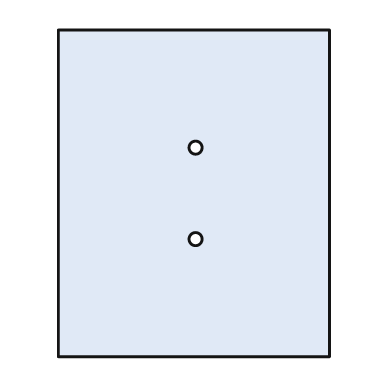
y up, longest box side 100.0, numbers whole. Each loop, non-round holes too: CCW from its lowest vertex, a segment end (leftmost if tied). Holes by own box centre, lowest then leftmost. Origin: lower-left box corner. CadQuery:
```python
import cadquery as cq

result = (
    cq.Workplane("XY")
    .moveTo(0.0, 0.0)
    .lineTo(83.0, 0.0)
    .lineTo(83.0, 100.0)
    .lineTo(0.0, 100.0)
    .close()
    .moveTo(42.0, 36.0)
    .circle(2.0)
    .moveTo(42.0, 64.0)
    .circle(2.0)
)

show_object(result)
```